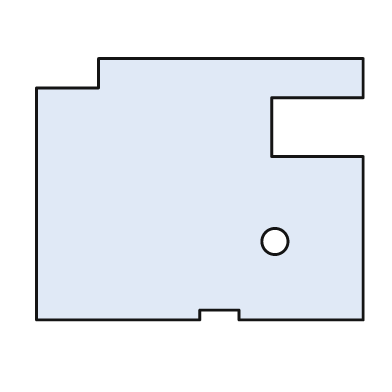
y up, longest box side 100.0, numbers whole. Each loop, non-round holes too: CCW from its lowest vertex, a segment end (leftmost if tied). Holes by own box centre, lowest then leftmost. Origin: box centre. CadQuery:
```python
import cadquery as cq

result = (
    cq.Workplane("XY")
    .moveTo(-50.0, -40.0)
    .lineTo(0.0, -40.0)
    .lineTo(0.0, -37.0)
    .lineTo(12.0, -37.0)
    .lineTo(12.0, -40.0)
    .lineTo(50.0, -40.0)
    .lineTo(50.0, 10.0)
    .lineTo(22.0, 10.0)
    .lineTo(22.0, 28.0)
    .lineTo(50.0, 28.0)
    .lineTo(50.0, 40.0)
    .lineTo(-31.0, 40.0)
    .lineTo(-31.0, 31.0)
    .lineTo(-50.0, 31.0)
    .close()
    .moveTo(23.0, -16.0)
    .circle(4.0)
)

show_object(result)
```